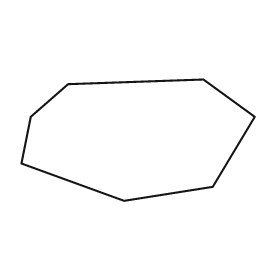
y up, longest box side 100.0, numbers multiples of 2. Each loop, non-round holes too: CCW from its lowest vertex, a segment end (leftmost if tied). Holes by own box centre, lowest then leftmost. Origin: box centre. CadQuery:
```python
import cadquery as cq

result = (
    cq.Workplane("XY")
    .moveTo(-6.0, -26.0)
    .lineTo(32.0, -20.0)
    .lineTo(50.0, 10.0)
    .lineTo(28.0, 26.0)
    .lineTo(-30.0, 24.0)
    .lineTo(-46.0, 10.0)
    .lineTo(-50.0, -10.0)
    .close()
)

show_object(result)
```